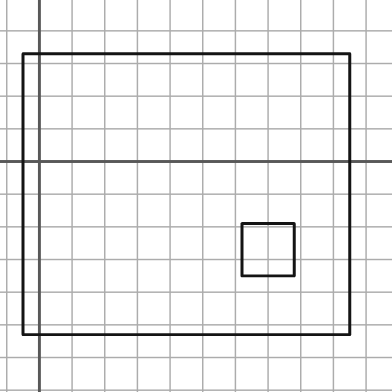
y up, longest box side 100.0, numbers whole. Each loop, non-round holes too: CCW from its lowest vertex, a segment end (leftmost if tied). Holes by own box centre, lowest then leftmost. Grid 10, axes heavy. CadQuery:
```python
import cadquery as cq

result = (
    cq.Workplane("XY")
    .moveTo(-5.0, -53.0)
    .lineTo(95.0, -53.0)
    .lineTo(95.0, 33.0)
    .lineTo(-5.0, 33.0)
    .close()
    .moveTo(62.0, -35.0)
    .lineTo(78.0, -35.0)
    .lineTo(78.0, -19.0)
    .lineTo(62.0, -19.0)
    .close()
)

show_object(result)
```